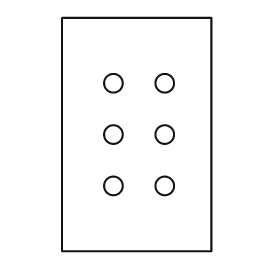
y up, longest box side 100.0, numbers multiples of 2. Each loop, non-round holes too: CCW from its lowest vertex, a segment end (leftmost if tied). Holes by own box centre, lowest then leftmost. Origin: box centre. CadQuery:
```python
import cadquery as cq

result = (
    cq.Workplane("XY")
    .moveTo(-32.0, -50.0)
    .lineTo(32.0, -50.0)
    .lineTo(32.0, 50.0)
    .lineTo(-32.0, 50.0)
    .close()
    .moveTo(-10.0, -22.0)
    .circle(4.0)
    .moveTo(12.0, -22.0)
    .circle(4.0)
    .moveTo(-10.0, 0.0)
    .circle(4.0)
    .moveTo(12.0, 0.0)
    .circle(4.0)
    .moveTo(-10.0, 22.0)
    .circle(4.0)
    .moveTo(12.0, 22.0)
    .circle(4.0)
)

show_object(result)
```